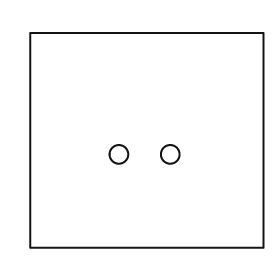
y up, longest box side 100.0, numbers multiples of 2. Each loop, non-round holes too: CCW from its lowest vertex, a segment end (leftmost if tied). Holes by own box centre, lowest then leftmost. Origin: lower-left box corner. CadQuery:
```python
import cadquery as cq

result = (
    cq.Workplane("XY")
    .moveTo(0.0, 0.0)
    .lineTo(100.0, 0.0)
    .lineTo(100.0, 92.0)
    .lineTo(0.0, 92.0)
    .close()
    .moveTo(38.0, 40.0)
    .circle(4.0)
    .moveTo(60.0, 40.0)
    .circle(4.0)
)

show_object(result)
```